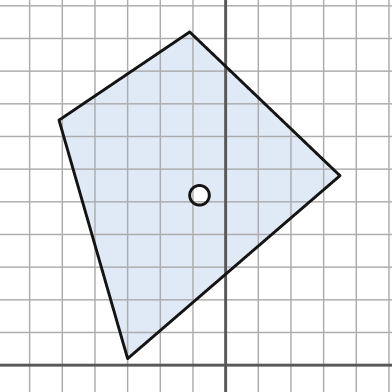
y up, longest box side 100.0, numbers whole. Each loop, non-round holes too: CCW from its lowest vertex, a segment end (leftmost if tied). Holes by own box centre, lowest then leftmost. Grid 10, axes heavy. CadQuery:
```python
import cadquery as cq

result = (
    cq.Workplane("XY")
    .moveTo(-30.0, 2.0)
    .lineTo(35.0, 58.0)
    .lineTo(-11.0, 102.0)
    .lineTo(-51.0, 75.0)
    .close()
    .moveTo(-8.0, 52.0)
    .circle(3.0)
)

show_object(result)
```